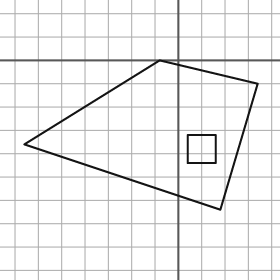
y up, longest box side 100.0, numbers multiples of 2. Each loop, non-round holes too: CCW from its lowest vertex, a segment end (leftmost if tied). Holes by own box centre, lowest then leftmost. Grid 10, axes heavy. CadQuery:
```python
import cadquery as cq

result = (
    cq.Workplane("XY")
    .moveTo(18.0, -64.0)
    .lineTo(34.0, -10.0)
    .lineTo(-8.0, 0.0)
    .lineTo(-66.0, -36.0)
    .close()
    .moveTo(4.0, -44.0)
    .lineTo(16.0, -44.0)
    .lineTo(16.0, -32.0)
    .lineTo(4.0, -32.0)
    .close()
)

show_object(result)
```